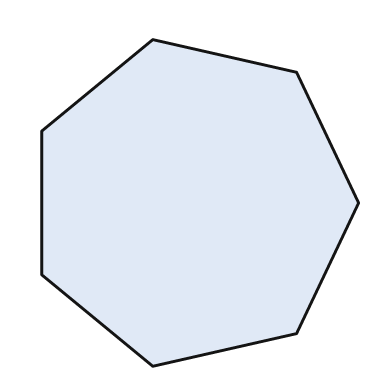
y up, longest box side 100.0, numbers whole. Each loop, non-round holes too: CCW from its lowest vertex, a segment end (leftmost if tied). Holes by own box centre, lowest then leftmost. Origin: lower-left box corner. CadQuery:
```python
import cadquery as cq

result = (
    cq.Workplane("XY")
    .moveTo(34.0, 0.0)
    .lineTo(78.0, 10.0)
    .lineTo(97.0, 50.0)
    .lineTo(78.0, 90.0)
    .lineTo(34.0, 100.0)
    .lineTo(0.0, 72.0)
    .lineTo(0.0, 28.0)
    .close()
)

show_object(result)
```